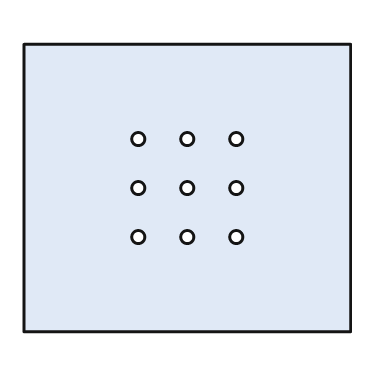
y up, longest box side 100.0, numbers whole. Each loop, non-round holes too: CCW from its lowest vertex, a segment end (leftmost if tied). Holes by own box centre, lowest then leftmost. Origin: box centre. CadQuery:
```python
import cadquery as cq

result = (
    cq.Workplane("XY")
    .moveTo(-50.0, -44.0)
    .lineTo(50.0, -44.0)
    .lineTo(50.0, 44.0)
    .lineTo(-50.0, 44.0)
    .close()
    .moveTo(-15.0, -15.0)
    .circle(2.0)
    .moveTo(0.0, -15.0)
    .circle(2.0)
    .moveTo(15.0, -15.0)
    .circle(2.0)
    .moveTo(-15.0, 0.0)
    .circle(2.0)
    .moveTo(0.0, 0.0)
    .circle(2.0)
    .moveTo(15.0, 0.0)
    .circle(2.0)
    .moveTo(-15.0, 15.0)
    .circle(2.0)
    .moveTo(0.0, 15.0)
    .circle(2.0)
    .moveTo(15.0, 15.0)
    .circle(2.0)
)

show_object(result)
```